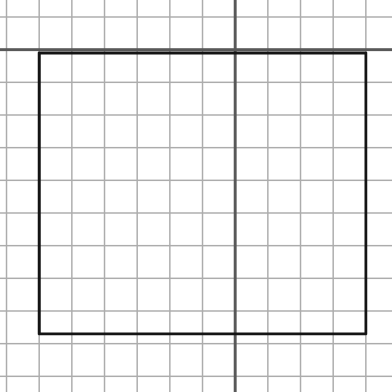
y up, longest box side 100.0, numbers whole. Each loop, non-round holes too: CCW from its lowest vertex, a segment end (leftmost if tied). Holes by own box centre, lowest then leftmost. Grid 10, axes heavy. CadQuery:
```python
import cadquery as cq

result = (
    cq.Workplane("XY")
    .moveTo(-60.0, -87.0)
    .lineTo(40.0, -87.0)
    .lineTo(40.0, -1.0)
    .lineTo(-60.0, -1.0)
    .close()
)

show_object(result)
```